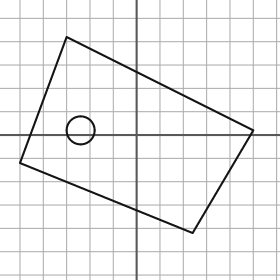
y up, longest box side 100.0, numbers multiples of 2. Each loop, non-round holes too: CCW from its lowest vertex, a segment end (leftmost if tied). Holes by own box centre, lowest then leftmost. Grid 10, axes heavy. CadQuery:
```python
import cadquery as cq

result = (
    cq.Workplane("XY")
    .moveTo(24.0, -42.0)
    .lineTo(50.0, 2.0)
    .lineTo(-30.0, 42.0)
    .lineTo(-50.0, -12.0)
    .close()
    .moveTo(-24.0, 2.0)
    .circle(6.0)
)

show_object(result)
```